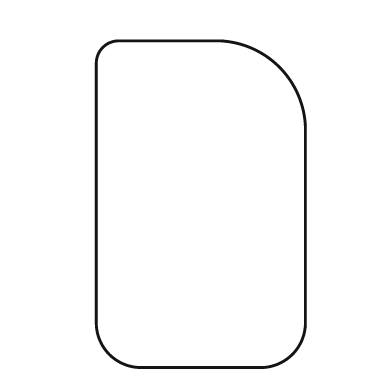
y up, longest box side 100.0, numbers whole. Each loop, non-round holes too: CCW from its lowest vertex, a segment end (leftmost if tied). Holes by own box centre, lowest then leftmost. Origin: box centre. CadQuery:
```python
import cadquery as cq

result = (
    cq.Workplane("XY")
    .moveTo(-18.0, -50.0)
    .lineTo(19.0, -50.0)
    .threePointArc((28.0, -46.0), (32.0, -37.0))
    .lineTo(32.0, 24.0)
    .threePointArc((24.0, 42.0), (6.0, 50.0))
    .lineTo(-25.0, 50.0)
    .threePointArc((-30.0, 48.0), (-32.0, 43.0))
    .lineTo(-32.0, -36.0)
    .threePointArc((-28.0, -46.0), (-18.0, -50.0))
    .close()
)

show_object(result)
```